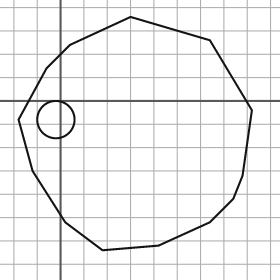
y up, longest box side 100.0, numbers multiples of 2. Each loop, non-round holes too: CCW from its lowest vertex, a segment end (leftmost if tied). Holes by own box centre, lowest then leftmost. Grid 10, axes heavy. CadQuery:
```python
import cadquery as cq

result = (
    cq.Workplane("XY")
    .moveTo(18.0, -64.0)
    .lineTo(42.0, -62.0)
    .lineTo(64.0, -52.0)
    .lineTo(74.0, -42.0)
    .lineTo(78.0, -32.0)
    .lineTo(82.0, -4.0)
    .lineTo(64.0, 26.0)
    .lineTo(30.0, 36.0)
    .lineTo(4.0, 24.0)
    .lineTo(-6.0, 14.0)
    .lineTo(-18.0, -8.0)
    .lineTo(-12.0, -30.0)
    .lineTo(2.0, -52.0)
    .close()
    .moveTo(-2.0, -8.0)
    .circle(8.0)
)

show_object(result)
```